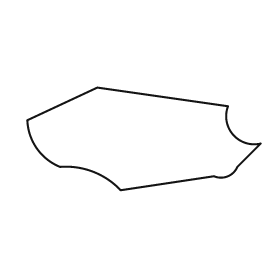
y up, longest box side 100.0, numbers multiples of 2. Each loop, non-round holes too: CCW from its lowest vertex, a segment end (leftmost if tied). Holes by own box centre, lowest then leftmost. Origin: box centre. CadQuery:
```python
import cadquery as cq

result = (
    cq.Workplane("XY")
    .moveTo(-10.0, -22.0)
    .lineTo(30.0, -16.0)
    .threePointArc((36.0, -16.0), (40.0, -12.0))
    .lineTo(50.0, -2.0)
    .threePointArc((38.0, 2.0), (36.0, 14.0))
    .lineTo(-20.0, 22.0)
    .lineTo(-50.0, 8.0)
    .threePointArc((-46.0, -4.0), (-36.0, -12.0))
    .threePointArc((-22.0, -14.0), (-10.0, -22.0))
    .close()
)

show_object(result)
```